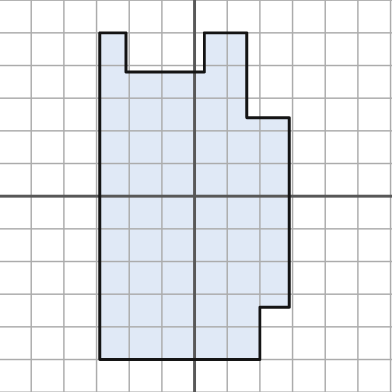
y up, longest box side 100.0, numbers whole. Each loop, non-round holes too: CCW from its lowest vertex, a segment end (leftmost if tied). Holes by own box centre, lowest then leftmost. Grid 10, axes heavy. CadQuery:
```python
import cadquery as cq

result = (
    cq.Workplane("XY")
    .moveTo(-29.0, -50.0)
    .lineTo(20.0, -50.0)
    .lineTo(20.0, -34.0)
    .lineTo(29.0, -34.0)
    .lineTo(29.0, 24.0)
    .lineTo(16.0, 24.0)
    .lineTo(16.0, 50.0)
    .lineTo(3.0, 50.0)
    .lineTo(3.0, 38.0)
    .lineTo(-21.0, 38.0)
    .lineTo(-21.0, 50.0)
    .lineTo(-29.0, 50.0)
    .close()
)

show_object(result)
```